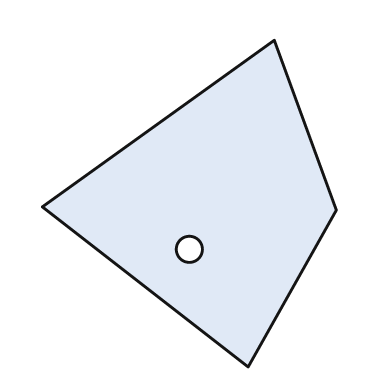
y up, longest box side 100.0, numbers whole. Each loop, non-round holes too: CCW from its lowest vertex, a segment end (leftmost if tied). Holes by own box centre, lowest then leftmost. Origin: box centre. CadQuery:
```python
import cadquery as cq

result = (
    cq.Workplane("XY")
    .moveTo(18.0, -50.0)
    .lineTo(45.0, -2.0)
    .lineTo(26.0, 50.0)
    .lineTo(-45.0, -1.0)
    .close()
    .moveTo(0.0, -14.0)
    .circle(4.0)
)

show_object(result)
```